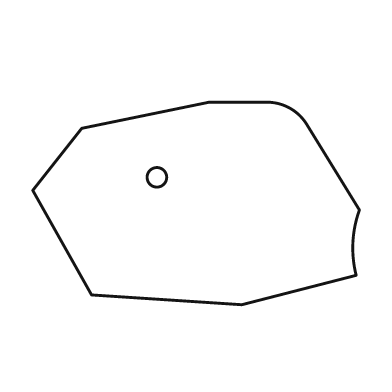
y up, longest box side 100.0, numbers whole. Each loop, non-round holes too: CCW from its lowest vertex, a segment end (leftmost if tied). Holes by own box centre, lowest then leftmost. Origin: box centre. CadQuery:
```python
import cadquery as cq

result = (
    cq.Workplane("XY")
    .moveTo(14.0, -31.0)
    .lineTo(49.0, -22.0)
    .threePointArc((48.0, -12.0), (50.0, -2.0))
    .lineTo(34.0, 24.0)
    .threePointArc((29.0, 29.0), (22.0, 31.0))
    .lineTo(4.0, 31.0)
    .lineTo(-35.0, 23.0)
    .lineTo(-50.0, 4.0)
    .lineTo(-32.0, -28.0)
    .close()
    .moveTo(-12.0, 8.0)
    .circle(3.0)
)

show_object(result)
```